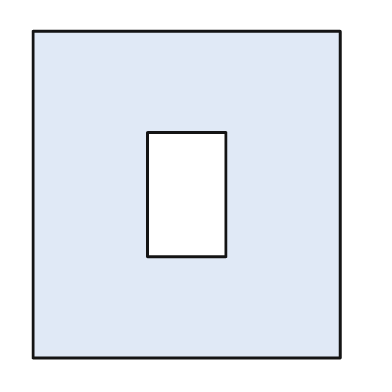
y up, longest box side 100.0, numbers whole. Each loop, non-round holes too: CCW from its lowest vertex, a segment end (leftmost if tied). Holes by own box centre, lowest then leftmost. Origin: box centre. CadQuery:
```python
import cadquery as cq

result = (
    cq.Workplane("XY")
    .moveTo(-47.0, -50.0)
    .lineTo(47.0, -50.0)
    .lineTo(47.0, 50.0)
    .lineTo(-47.0, 50.0)
    .close()
    .moveTo(-12.0, -19.0)
    .lineTo(12.0, -19.0)
    .lineTo(12.0, 19.0)
    .lineTo(-12.0, 19.0)
    .close()
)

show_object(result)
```